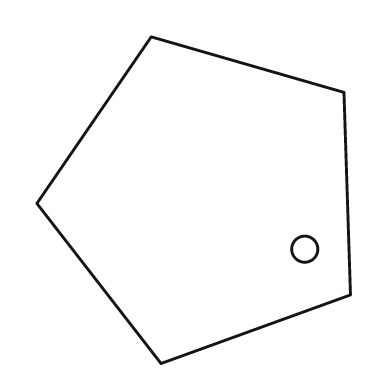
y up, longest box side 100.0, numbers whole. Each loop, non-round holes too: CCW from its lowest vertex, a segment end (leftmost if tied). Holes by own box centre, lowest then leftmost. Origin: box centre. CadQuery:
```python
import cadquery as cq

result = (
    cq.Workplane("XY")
    .moveTo(-10.0, -50.0)
    .lineTo(48.0, -29.0)
    .lineTo(46.0, 33.0)
    .lineTo(-13.0, 50.0)
    .lineTo(-48.0, -1.0)
    .close()
    .moveTo(34.0, -15.0)
    .circle(4.0)
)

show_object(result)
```